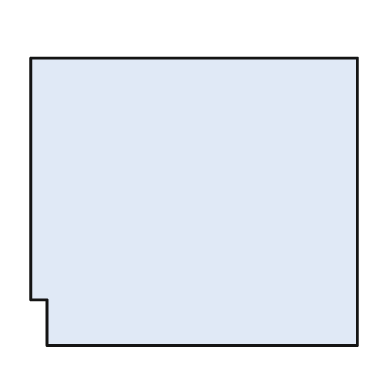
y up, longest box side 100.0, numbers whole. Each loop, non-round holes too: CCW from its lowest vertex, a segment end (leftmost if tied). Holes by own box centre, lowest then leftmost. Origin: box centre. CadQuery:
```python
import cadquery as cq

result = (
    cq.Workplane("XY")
    .moveTo(-45.0, -44.0)
    .lineTo(50.0, -44.0)
    .lineTo(50.0, 44.0)
    .lineTo(-50.0, 44.0)
    .lineTo(-50.0, -30.0)
    .lineTo(-45.0, -30.0)
    .close()
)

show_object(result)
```